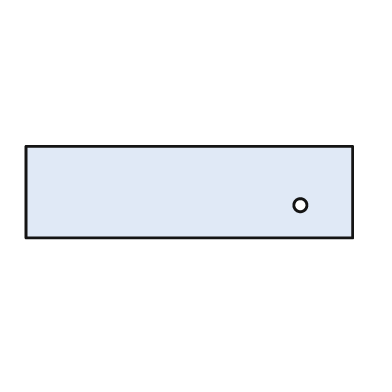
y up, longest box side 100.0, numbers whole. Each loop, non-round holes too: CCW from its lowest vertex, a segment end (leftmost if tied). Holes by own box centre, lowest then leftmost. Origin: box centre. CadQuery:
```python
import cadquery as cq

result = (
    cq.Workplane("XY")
    .moveTo(-50.0, -14.0)
    .lineTo(50.0, -14.0)
    .lineTo(50.0, 14.0)
    .lineTo(-50.0, 14.0)
    .close()
    .moveTo(34.0, -4.0)
    .circle(2.0)
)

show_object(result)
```